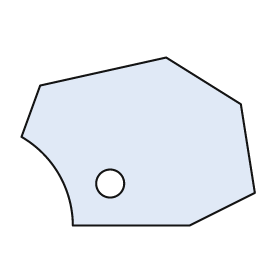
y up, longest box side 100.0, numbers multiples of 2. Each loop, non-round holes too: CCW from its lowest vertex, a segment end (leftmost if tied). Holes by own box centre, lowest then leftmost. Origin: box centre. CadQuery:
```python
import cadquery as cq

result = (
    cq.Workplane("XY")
    .moveTo(-28.0, -36.0)
    .lineTo(22.0, -36.0)
    .lineTo(50.0, -22.0)
    .lineTo(44.0, 16.0)
    .lineTo(12.0, 36.0)
    .lineTo(-42.0, 24.0)
    .lineTo(-50.0, 2.0)
    .threePointArc((-34.0, -14.0), (-28.0, -36.0))
    .close()
    .moveTo(-12.0, -18.0)
    .circle(6.0)
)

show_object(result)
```